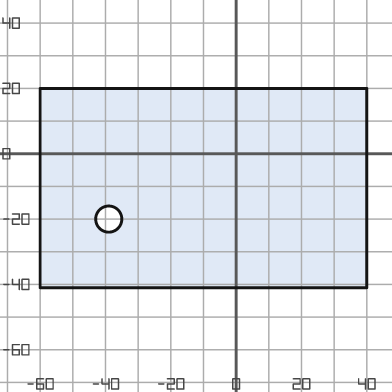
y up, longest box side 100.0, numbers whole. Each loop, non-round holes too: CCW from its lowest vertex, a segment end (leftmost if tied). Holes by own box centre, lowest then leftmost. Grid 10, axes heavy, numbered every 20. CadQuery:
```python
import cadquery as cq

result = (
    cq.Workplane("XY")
    .moveTo(-60.0, -41.0)
    .lineTo(40.0, -41.0)
    .lineTo(40.0, 20.0)
    .lineTo(-60.0, 20.0)
    .close()
    .moveTo(-39.0, -20.0)
    .circle(4.0)
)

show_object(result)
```